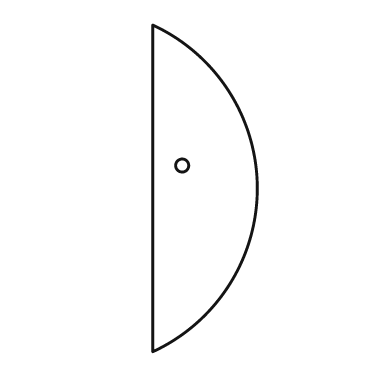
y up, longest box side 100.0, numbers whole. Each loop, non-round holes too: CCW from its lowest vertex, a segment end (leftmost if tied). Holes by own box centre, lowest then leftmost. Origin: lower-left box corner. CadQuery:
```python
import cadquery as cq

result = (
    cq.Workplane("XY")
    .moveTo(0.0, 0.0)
    .threePointArc((32.0, 50.0), (0.0, 100.0))
    .close()
    .moveTo(9.0, 57.0)
    .circle(2.0)
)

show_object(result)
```